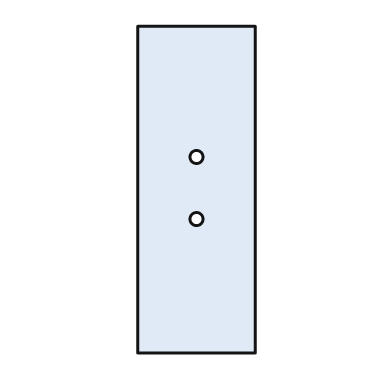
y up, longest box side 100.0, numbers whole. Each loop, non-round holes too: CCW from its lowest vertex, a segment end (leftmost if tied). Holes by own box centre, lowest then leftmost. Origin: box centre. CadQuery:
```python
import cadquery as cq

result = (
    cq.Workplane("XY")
    .moveTo(-18.0, -50.0)
    .lineTo(18.0, -50.0)
    .lineTo(18.0, 50.0)
    .lineTo(-18.0, 50.0)
    .close()
    .moveTo(0.0, -9.0)
    .circle(2.0)
    .moveTo(0.0, 10.0)
    .circle(2.0)
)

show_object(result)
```